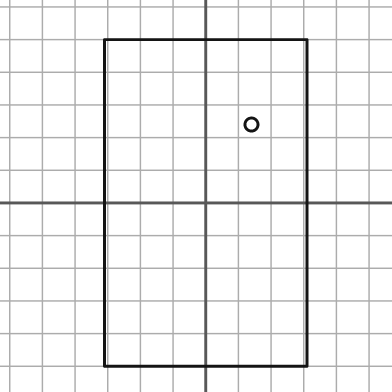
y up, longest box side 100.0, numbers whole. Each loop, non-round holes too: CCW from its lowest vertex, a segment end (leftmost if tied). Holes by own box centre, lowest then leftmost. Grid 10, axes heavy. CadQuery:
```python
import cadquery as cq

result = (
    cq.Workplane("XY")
    .moveTo(-31.0, -50.0)
    .lineTo(31.0, -50.0)
    .lineTo(31.0, 50.0)
    .lineTo(-31.0, 50.0)
    .close()
    .moveTo(14.0, 24.0)
    .circle(2.0)
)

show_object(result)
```